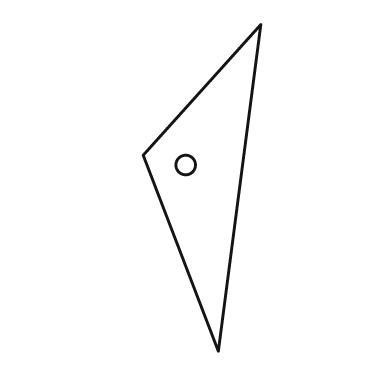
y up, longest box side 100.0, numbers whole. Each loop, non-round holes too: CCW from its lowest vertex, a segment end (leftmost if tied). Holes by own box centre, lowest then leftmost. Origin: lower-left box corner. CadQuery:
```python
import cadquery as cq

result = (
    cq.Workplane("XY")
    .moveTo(23.0, 0.0)
    .lineTo(36.0, 100.0)
    .lineTo(0.0, 60.0)
    .close()
    .moveTo(13.0, 57.0)
    .circle(3.0)
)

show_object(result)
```